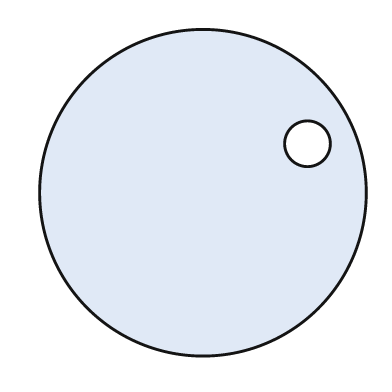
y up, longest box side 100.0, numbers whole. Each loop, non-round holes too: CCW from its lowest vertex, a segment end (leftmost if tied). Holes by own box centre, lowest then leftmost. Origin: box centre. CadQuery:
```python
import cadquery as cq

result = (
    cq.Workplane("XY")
    .moveTo(0.0, 0.0)
    .circle(50.0)
    .moveTo(32.0, 15.0)
    .circle(7.0)
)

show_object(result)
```